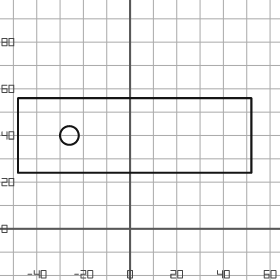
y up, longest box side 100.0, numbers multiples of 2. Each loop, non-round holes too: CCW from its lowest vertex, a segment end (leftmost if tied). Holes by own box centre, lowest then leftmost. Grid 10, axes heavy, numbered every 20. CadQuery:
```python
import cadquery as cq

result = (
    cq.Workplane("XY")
    .moveTo(-48.0, 24.0)
    .lineTo(52.0, 24.0)
    .lineTo(52.0, 56.0)
    .lineTo(-48.0, 56.0)
    .close()
    .moveTo(-26.0, 40.0)
    .circle(4.0)
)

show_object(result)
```